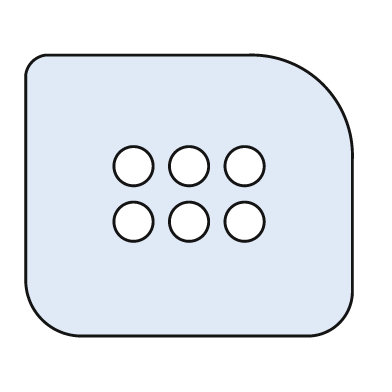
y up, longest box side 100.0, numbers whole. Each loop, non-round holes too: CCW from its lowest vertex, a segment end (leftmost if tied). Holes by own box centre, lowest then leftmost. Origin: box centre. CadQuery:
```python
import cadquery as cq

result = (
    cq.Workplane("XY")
    .moveTo(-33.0, -43.0)
    .lineTo(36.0, -43.0)
    .threePointArc((46.0, -39.0), (50.0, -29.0))
    .lineTo(50.0, 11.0)
    .threePointArc((41.0, 34.0), (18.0, 43.0))
    .lineTo(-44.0, 43.0)
    .threePointArc((-48.0, 41.0), (-50.0, 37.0))
    .lineTo(-50.0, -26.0)
    .threePointArc((-45.0, -38.0), (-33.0, -43.0))
    .close()
    .moveTo(-17.0, -8.0)
    .circle(6.0)
    .moveTo(0.0, -8.0)
    .circle(6.0)
    .moveTo(17.0, -8.0)
    .circle(6.0)
    .moveTo(-17.0, 9.0)
    .circle(6.0)
    .moveTo(0.0, 9.0)
    .circle(6.0)
    .moveTo(17.0, 9.0)
    .circle(6.0)
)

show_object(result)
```